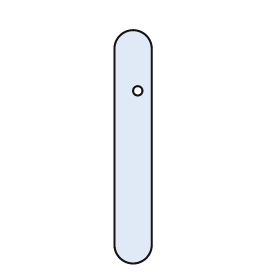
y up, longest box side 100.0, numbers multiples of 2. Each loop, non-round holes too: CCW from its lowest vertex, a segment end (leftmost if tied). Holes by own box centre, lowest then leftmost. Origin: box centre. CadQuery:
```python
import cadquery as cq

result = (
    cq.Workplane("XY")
    .moveTo(-8.0, -42.0)
    .threePointArc((0.0, -50.0), (8.0, -42.0))
    .lineTo(8.0, 42.0)
    .threePointArc((0.0, 50.0), (-8.0, 42.0))
    .close()
    .moveTo(2.0, 24.0)
    .circle(2.0)
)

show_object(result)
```